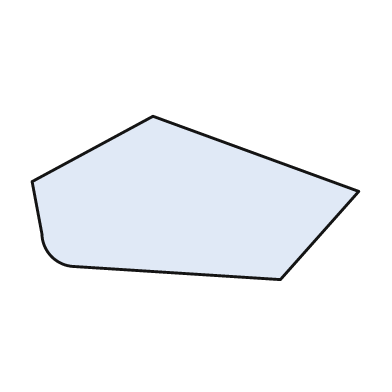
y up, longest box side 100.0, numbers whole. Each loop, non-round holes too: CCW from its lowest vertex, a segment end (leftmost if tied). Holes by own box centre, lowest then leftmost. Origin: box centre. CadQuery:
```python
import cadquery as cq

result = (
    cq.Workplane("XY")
    .moveTo(26.0, -25.0)
    .lineTo(50.0, 2.0)
    .lineTo(-13.0, 25.0)
    .lineTo(-50.0, 5.0)
    .lineTo(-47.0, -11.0)
    .threePointArc((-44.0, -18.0), (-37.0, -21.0))
    .close()
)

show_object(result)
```